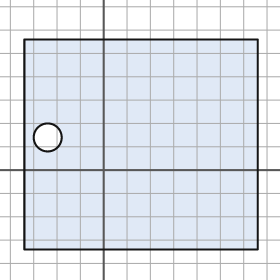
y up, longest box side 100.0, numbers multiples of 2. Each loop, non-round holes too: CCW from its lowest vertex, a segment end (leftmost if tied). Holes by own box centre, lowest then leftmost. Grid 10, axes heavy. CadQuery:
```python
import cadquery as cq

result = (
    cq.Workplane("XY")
    .moveTo(-34.0, -34.0)
    .lineTo(66.0, -34.0)
    .lineTo(66.0, 56.0)
    .lineTo(-34.0, 56.0)
    .close()
    .moveTo(-24.0, 14.0)
    .circle(6.0)
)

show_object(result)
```